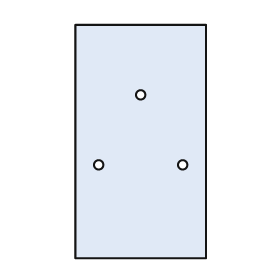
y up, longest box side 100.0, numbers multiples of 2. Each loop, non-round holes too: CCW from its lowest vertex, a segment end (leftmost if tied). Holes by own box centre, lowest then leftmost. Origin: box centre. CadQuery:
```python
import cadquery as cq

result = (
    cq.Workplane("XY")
    .moveTo(-28.0, -50.0)
    .lineTo(28.0, -50.0)
    .lineTo(28.0, 50.0)
    .lineTo(-28.0, 50.0)
    .close()
    .moveTo(-18.0, -10.0)
    .circle(2.0)
    .moveTo(18.0, -10.0)
    .circle(2.0)
    .moveTo(0.0, 20.0)
    .circle(2.0)
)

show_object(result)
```